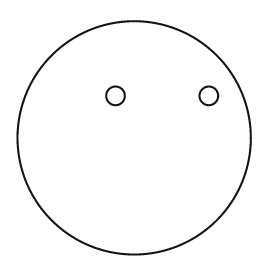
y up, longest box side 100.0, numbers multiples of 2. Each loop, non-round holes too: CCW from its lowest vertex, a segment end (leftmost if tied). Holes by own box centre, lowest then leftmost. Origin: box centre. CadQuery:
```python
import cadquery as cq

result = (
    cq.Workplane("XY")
    .moveTo(0.0, 0.0)
    .circle(50.0)
    .moveTo(-8.0, 18.0)
    .circle(4.0)
    .moveTo(32.0, 18.0)
    .circle(4.0)
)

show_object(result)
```